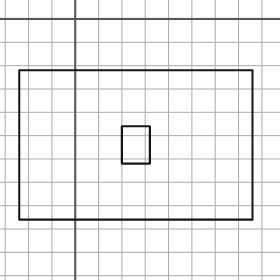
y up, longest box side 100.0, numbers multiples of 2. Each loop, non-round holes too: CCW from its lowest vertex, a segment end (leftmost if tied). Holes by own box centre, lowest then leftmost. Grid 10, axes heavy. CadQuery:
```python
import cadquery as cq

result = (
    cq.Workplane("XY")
    .moveTo(-24.0, -86.0)
    .lineTo(76.0, -86.0)
    .lineTo(76.0, -22.0)
    .lineTo(-24.0, -22.0)
    .close()
    .moveTo(20.0, -62.0)
    .lineTo(32.0, -62.0)
    .lineTo(32.0, -46.0)
    .lineTo(20.0, -46.0)
    .close()
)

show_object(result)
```